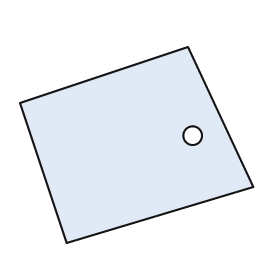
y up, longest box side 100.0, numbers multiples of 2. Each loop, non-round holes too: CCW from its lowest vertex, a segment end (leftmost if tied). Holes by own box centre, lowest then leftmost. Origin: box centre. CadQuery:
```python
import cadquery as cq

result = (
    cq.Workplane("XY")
    .moveTo(-30.0, -42.0)
    .lineTo(50.0, -18.0)
    .lineTo(22.0, 42.0)
    .lineTo(-50.0, 18.0)
    .close()
    .moveTo(24.0, 4.0)
    .circle(4.0)
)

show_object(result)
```